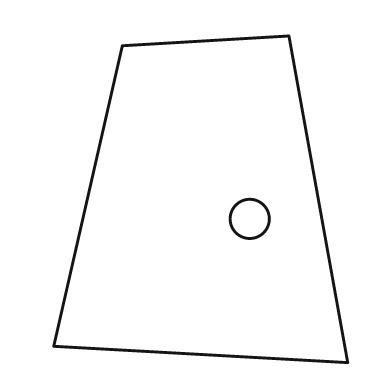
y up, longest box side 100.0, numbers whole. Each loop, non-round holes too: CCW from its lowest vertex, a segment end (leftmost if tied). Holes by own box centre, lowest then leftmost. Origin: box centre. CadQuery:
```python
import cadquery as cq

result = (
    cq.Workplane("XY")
    .moveTo(45.0, -50.0)
    .lineTo(27.0, 50.0)
    .lineTo(-24.0, 47.0)
    .lineTo(-45.0, -45.0)
    .close()
    .moveTo(15.0, -6.0)
    .circle(6.0)
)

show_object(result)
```